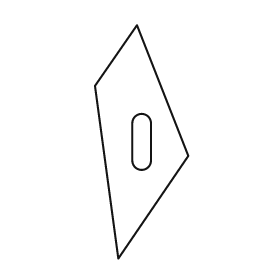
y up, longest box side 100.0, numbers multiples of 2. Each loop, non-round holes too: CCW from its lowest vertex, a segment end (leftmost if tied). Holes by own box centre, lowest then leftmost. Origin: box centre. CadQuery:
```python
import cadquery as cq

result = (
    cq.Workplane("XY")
    .moveTo(-10.0, -50.0)
    .lineTo(20.0, -6.0)
    .lineTo(-2.0, 50.0)
    .lineTo(-20.0, 24.0)
    .close()
    .moveTo(-4.0, -8.0)
    .threePointArc((0.0, -12.0), (4.0, -8.0))
    .lineTo(4.0, 8.0)
    .threePointArc((0.0, 12.0), (-4.0, 8.0))
    .close()
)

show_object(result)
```